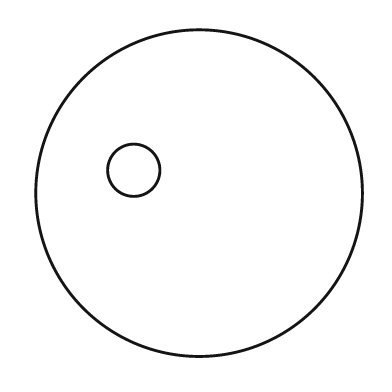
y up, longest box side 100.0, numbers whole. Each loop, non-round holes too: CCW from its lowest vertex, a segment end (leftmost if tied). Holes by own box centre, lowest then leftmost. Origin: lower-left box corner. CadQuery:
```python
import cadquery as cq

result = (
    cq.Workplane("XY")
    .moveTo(50.0, 50.0)
    .circle(50.0)
    .moveTo(30.0, 57.0)
    .circle(8.0)
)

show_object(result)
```